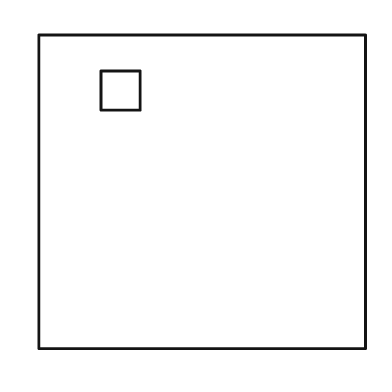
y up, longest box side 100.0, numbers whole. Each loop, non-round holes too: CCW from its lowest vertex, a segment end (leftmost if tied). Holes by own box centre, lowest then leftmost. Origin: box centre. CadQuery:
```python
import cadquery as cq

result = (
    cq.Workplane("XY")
    .moveTo(-50.0, -48.0)
    .lineTo(50.0, -48.0)
    .lineTo(50.0, 48.0)
    .lineTo(-50.0, 48.0)
    .close()
    .moveTo(-31.0, 25.0)
    .lineTo(-19.0, 25.0)
    .lineTo(-19.0, 37.0)
    .lineTo(-31.0, 37.0)
    .close()
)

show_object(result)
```